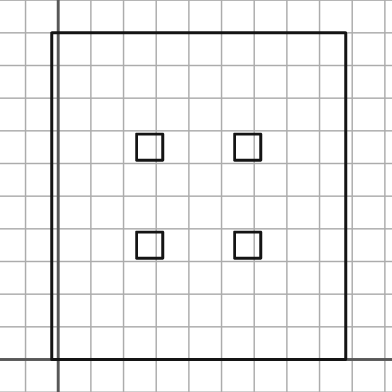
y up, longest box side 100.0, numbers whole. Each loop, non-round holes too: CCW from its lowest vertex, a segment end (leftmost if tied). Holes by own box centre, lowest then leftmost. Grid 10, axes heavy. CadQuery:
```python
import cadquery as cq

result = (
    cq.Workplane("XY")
    .moveTo(-2.0, 0.0)
    .lineTo(88.0, 0.0)
    .lineTo(88.0, 100.0)
    .lineTo(-2.0, 100.0)
    .close()
    .moveTo(24.0, 31.0)
    .lineTo(32.0, 31.0)
    .lineTo(32.0, 39.0)
    .lineTo(24.0, 39.0)
    .close()
    .moveTo(54.0, 31.0)
    .lineTo(62.0, 31.0)
    .lineTo(62.0, 39.0)
    .lineTo(54.0, 39.0)
    .close()
    .moveTo(24.0, 61.0)
    .lineTo(32.0, 61.0)
    .lineTo(32.0, 69.0)
    .lineTo(24.0, 69.0)
    .close()
    .moveTo(54.0, 61.0)
    .lineTo(62.0, 61.0)
    .lineTo(62.0, 69.0)
    .lineTo(54.0, 69.0)
    .close()
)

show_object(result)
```